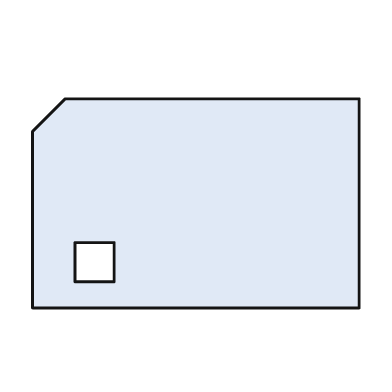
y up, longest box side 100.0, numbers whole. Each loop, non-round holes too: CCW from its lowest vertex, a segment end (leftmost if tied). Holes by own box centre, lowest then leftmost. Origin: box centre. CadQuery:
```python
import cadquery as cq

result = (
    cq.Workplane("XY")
    .moveTo(-50.0, -32.0)
    .lineTo(50.0, -32.0)
    .lineTo(50.0, 32.0)
    .lineTo(-40.0, 32.0)
    .lineTo(-50.0, 22.0)
    .close()
    .moveTo(-37.0, -24.0)
    .lineTo(-25.0, -24.0)
    .lineTo(-25.0, -12.0)
    .lineTo(-37.0, -12.0)
    .close()
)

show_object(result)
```